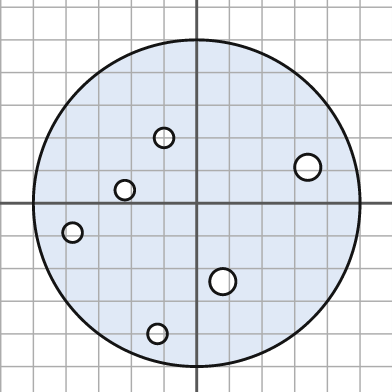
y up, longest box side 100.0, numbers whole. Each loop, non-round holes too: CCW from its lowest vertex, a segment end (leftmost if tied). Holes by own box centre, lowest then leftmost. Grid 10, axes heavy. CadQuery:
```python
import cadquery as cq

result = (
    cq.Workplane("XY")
    .moveTo(0.0, 0.0)
    .circle(50.0)
    .moveTo(-12.0, -40.0)
    .circle(3.0)
    .moveTo(8.0, -24.0)
    .circle(4.0)
    .moveTo(-38.0, -9.0)
    .circle(3.0)
    .moveTo(-22.0, 4.0)
    .circle(3.0)
    .moveTo(34.0, 11.0)
    .circle(4.0)
    .moveTo(-10.0, 20.0)
    .circle(3.0)
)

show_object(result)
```